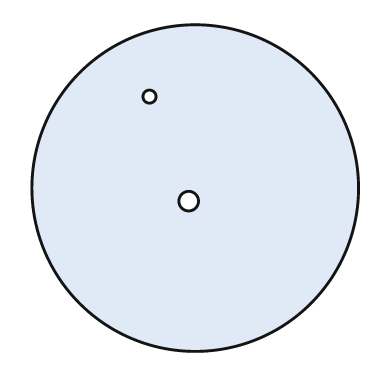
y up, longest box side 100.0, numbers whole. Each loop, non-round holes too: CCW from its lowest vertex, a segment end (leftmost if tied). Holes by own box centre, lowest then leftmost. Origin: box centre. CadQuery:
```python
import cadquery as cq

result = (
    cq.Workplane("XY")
    .moveTo(0.0, 0.0)
    .circle(50.0)
    .moveTo(-2.0, -4.0)
    .circle(3.0)
    .moveTo(-14.0, 28.0)
    .circle(2.0)
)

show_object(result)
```